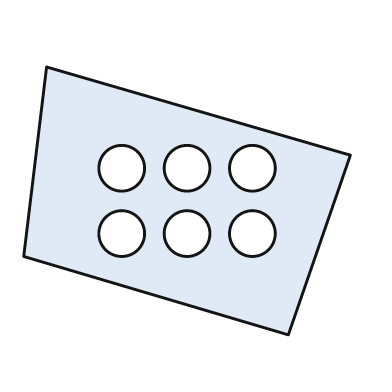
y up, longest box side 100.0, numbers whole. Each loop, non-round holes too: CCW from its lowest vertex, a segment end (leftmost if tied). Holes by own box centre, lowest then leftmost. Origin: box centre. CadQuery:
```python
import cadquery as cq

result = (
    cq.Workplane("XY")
    .moveTo(31.0, -41.0)
    .lineTo(50.0, 14.0)
    .lineTo(-43.0, 41.0)
    .lineTo(-50.0, -17.0)
    .close()
    .moveTo(-20.0, -10.0)
    .circle(7.0)
    .moveTo(0.0, -10.0)
    .circle(7.0)
    .moveTo(20.0, -10.0)
    .circle(7.0)
    .moveTo(-20.0, 10.0)
    .circle(7.0)
    .moveTo(0.0, 10.0)
    .circle(7.0)
    .moveTo(20.0, 10.0)
    .circle(7.0)
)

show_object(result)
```